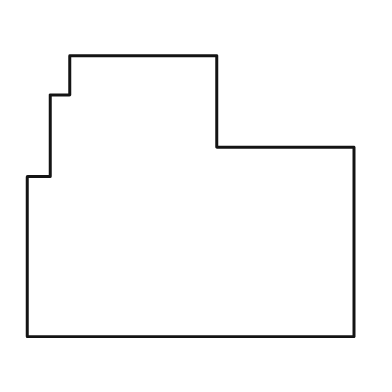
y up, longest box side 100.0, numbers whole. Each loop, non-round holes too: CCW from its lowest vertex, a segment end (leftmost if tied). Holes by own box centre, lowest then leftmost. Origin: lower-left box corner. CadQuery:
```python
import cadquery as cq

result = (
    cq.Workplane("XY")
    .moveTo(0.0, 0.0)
    .lineTo(100.0, 0.0)
    .lineTo(100.0, 58.0)
    .lineTo(58.0, 58.0)
    .lineTo(58.0, 86.0)
    .lineTo(13.0, 86.0)
    .lineTo(13.0, 74.0)
    .lineTo(7.0, 74.0)
    .lineTo(7.0, 49.0)
    .lineTo(0.0, 49.0)
    .close()
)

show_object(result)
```